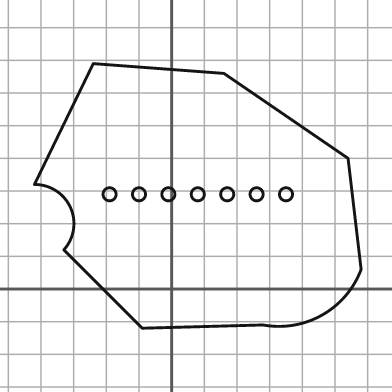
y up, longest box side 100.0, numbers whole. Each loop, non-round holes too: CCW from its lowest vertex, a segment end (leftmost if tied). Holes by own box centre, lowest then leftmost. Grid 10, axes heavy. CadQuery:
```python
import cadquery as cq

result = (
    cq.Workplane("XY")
    .moveTo(-9.0, -12.0)
    .lineTo(28.0, -11.0)
    .threePointArc((46.0, -8.0), (58.0, 6.0))
    .lineTo(54.0, 40.0)
    .lineTo(16.0, 66.0)
    .lineTo(-24.0, 69.0)
    .lineTo(-42.0, 32.0)
    .threePointArc((-31.0, 25.0), (-33.0, 12.0))
    .close()
    .moveTo(-19.0, 29.0)
    .circle(2.0)
    .moveTo(-10.0, 29.0)
    .circle(2.0)
    .moveTo(-1.0, 29.0)
    .circle(2.0)
    .moveTo(8.0, 29.0)
    .circle(2.0)
    .moveTo(17.0, 29.0)
    .circle(2.0)
    .moveTo(26.0, 29.0)
    .circle(2.0)
    .moveTo(35.0, 29.0)
    .circle(2.0)
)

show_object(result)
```